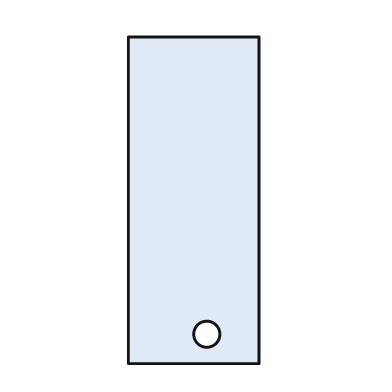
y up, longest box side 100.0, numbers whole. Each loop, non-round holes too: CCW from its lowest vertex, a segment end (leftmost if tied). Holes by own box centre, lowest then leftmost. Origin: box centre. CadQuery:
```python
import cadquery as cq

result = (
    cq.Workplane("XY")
    .moveTo(-20.0, -50.0)
    .lineTo(20.0, -50.0)
    .lineTo(20.0, 50.0)
    .lineTo(-20.0, 50.0)
    .close()
    .moveTo(4.0, -41.0)
    .circle(4.0)
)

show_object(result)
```